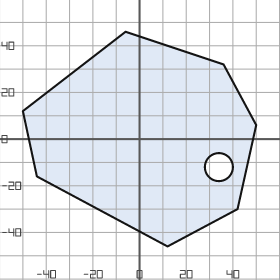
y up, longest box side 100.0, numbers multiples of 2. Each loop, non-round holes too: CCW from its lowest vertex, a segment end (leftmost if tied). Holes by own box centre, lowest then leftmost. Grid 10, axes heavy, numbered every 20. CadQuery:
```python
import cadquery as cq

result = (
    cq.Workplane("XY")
    .moveTo(12.0, -46.0)
    .lineTo(42.0, -30.0)
    .lineTo(50.0, 6.0)
    .lineTo(36.0, 32.0)
    .lineTo(-6.0, 46.0)
    .lineTo(-50.0, 12.0)
    .lineTo(-44.0, -16.0)
    .close()
    .moveTo(34.0, -12.0)
    .circle(6.0)
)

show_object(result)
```